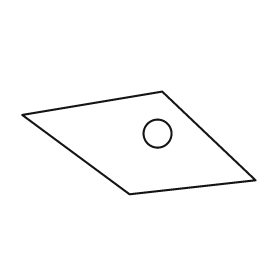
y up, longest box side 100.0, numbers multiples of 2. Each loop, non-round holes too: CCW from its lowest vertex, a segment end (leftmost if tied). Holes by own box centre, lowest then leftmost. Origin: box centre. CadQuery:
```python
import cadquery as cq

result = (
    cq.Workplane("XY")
    .moveTo(-4.0, -22.0)
    .lineTo(50.0, -16.0)
    .lineTo(10.0, 22.0)
    .lineTo(-50.0, 12.0)
    .close()
    .moveTo(8.0, 4.0)
    .circle(6.0)
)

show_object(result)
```